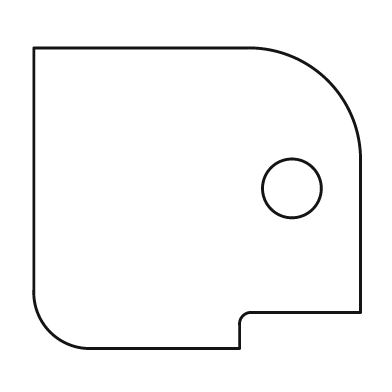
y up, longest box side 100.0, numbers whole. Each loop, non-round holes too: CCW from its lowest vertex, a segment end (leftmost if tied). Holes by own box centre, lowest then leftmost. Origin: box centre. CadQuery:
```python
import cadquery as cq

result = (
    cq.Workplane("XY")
    .moveTo(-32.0, -46.0)
    .lineTo(13.0, -46.0)
    .lineTo(13.0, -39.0)
    .threePointArc((14.0, -36.0), (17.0, -35.0))
    .lineTo(50.0, -35.0)
    .lineTo(50.0, 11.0)
    .threePointArc((40.0, 36.0), (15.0, 46.0))
    .lineTo(-50.0, 46.0)
    .lineTo(-50.0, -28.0)
    .threePointArc((-45.0, -41.0), (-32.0, -46.0))
    .close()
    .moveTo(29.0, 3.0)
    .circle(9.0)
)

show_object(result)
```